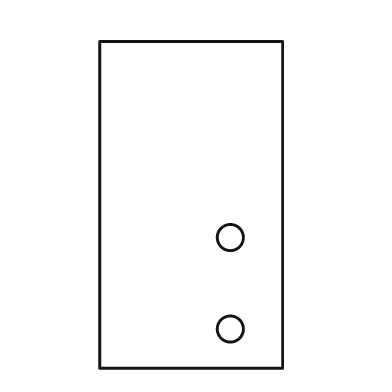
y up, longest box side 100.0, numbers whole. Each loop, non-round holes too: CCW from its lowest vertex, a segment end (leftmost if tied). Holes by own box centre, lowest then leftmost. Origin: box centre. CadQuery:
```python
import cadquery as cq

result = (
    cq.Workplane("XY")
    .moveTo(-28.0, -50.0)
    .lineTo(28.0, -50.0)
    .lineTo(28.0, 50.0)
    .lineTo(-28.0, 50.0)
    .close()
    .moveTo(12.0, -38.0)
    .circle(4.0)
    .moveTo(12.0, -10.0)
    .circle(4.0)
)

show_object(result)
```